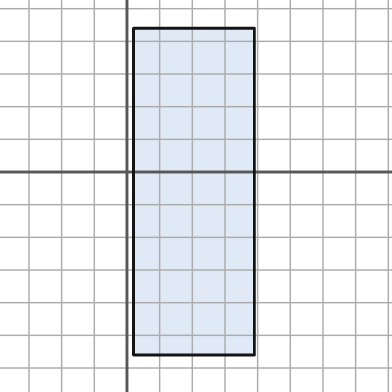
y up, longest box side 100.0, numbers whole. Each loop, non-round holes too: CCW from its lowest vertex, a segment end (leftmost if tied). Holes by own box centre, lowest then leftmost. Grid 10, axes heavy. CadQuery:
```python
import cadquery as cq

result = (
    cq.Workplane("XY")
    .moveTo(2.0, -56.0)
    .lineTo(39.0, -56.0)
    .lineTo(39.0, 44.0)
    .lineTo(2.0, 44.0)
    .close()
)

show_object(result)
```